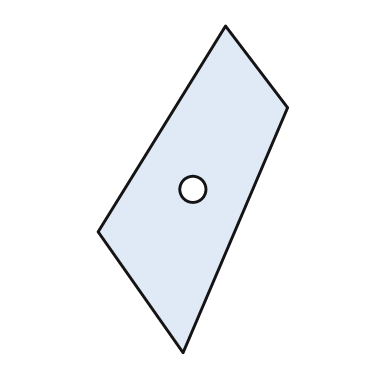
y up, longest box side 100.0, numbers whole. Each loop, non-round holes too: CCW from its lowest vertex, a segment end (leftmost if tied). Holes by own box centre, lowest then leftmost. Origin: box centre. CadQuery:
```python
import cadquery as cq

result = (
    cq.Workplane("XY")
    .moveTo(-3.0, -50.0)
    .lineTo(29.0, 25.0)
    .lineTo(10.0, 50.0)
    .lineTo(-29.0, -13.0)
    .close()
    .moveTo(0.0, 0.0)
    .circle(4.0)
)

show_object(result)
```